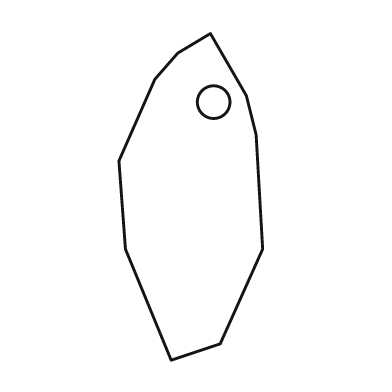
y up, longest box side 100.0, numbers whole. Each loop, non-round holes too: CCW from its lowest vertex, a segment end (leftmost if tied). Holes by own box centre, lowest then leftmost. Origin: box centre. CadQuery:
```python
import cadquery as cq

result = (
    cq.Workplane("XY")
    .moveTo(-6.0, -50.0)
    .lineTo(9.0, -45.0)
    .lineTo(22.0, -16.0)
    .lineTo(20.0, 19.0)
    .lineTo(17.0, 31.0)
    .lineTo(6.0, 50.0)
    .lineTo(-4.0, 44.0)
    .lineTo(-11.0, 36.0)
    .lineTo(-22.0, 11.0)
    .lineTo(-20.0, -16.0)
    .close()
    .moveTo(7.0, 29.0)
    .circle(5.0)
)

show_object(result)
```